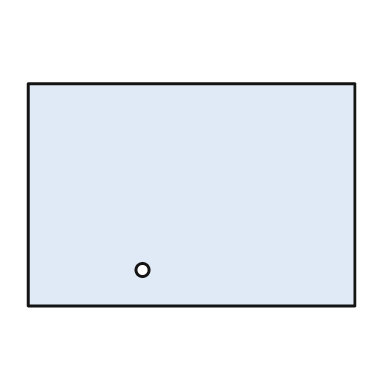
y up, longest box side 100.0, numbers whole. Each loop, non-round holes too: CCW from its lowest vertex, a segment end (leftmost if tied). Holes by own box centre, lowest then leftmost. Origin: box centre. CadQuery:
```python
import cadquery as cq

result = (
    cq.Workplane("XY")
    .moveTo(-50.0, -34.0)
    .lineTo(50.0, -34.0)
    .lineTo(50.0, 34.0)
    .lineTo(-50.0, 34.0)
    .close()
    .moveTo(-15.0, -23.0)
    .circle(2.0)
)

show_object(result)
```